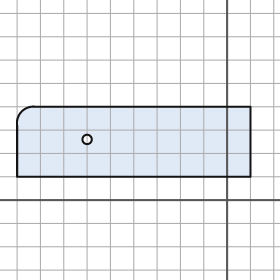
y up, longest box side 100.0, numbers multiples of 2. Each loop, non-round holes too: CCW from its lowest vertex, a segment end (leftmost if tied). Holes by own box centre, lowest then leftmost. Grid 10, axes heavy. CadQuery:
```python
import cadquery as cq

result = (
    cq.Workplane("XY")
    .moveTo(-90.0, 10.0)
    .lineTo(10.0, 10.0)
    .lineTo(10.0, 40.0)
    .lineTo(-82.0, 40.0)
    .threePointArc((-88.0, 38.0), (-90.0, 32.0))
    .close()
    .moveTo(-60.0, 26.0)
    .circle(2.0)
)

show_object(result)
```